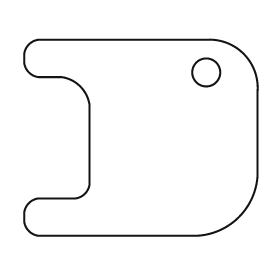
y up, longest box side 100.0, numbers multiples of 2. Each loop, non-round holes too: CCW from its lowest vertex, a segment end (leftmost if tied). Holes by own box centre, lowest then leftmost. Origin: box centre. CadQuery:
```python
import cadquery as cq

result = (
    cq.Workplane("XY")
    .moveTo(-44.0, -42.0)
    .lineTo(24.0, -42.0)
    .threePointArc((42.0, -34.0), (50.0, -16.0))
    .lineTo(50.0, 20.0)
    .threePointArc((44.0, 36.0), (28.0, 42.0))
    .lineTo(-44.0, 42.0)
    .threePointArc((-48.0, 40.0), (-50.0, 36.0))
    .lineTo(-50.0, 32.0)
    .threePointArc((-48.0, 28.0), (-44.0, 26.0))
    .lineTo(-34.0, 26.0)
    .threePointArc((-26.0, 22.0), (-22.0, 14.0))
    .lineTo(-22.0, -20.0)
    .threePointArc((-24.0, -24.0), (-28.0, -26.0))
    .lineTo(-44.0, -26.0)
    .threePointArc((-48.0, -28.0), (-50.0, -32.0))
    .lineTo(-50.0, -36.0)
    .threePointArc((-48.0, -40.0), (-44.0, -42.0))
    .close()
    .moveTo(28.0, 28.0)
    .circle(6.0)
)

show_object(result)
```